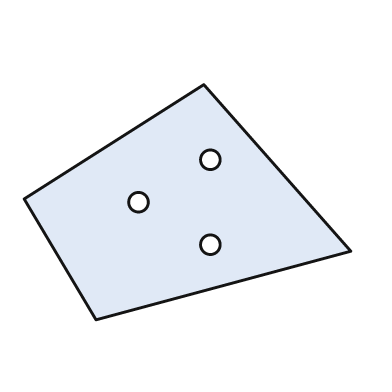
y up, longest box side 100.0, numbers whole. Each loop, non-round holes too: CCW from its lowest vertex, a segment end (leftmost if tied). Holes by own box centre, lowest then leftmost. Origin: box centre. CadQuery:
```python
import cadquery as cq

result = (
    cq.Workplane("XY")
    .moveTo(-28.0, -36.0)
    .lineTo(50.0, -15.0)
    .lineTo(5.0, 36.0)
    .lineTo(-50.0, 1.0)
    .close()
    .moveTo(7.0, -13.0)
    .circle(3.0)
    .moveTo(-15.0, 0.0)
    .circle(3.0)
    .moveTo(7.0, 13.0)
    .circle(3.0)
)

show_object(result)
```